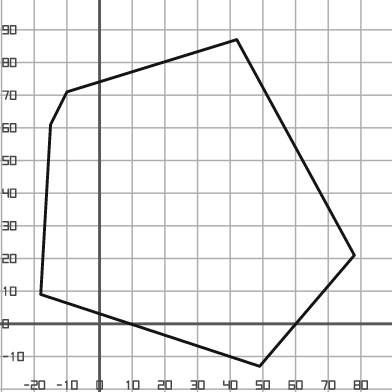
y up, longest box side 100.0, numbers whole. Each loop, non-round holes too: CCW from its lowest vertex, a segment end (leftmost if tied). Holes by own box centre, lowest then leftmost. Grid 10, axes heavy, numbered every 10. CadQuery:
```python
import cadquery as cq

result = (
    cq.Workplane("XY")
    .moveTo(49.0, -13.0)
    .lineTo(78.0, 21.0)
    .lineTo(42.0, 87.0)
    .lineTo(-10.0, 71.0)
    .lineTo(-15.0, 61.0)
    .lineTo(-18.0, 9.0)
    .close()
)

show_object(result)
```